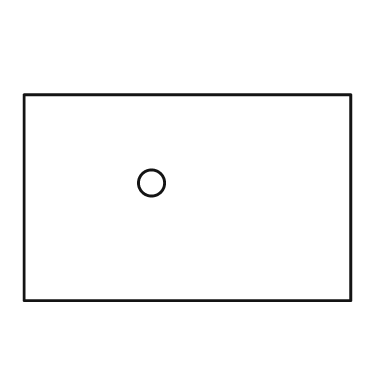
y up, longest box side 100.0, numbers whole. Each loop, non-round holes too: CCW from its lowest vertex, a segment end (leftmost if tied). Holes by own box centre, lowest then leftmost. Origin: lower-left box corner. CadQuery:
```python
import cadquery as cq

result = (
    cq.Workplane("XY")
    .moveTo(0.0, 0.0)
    .lineTo(100.0, 0.0)
    .lineTo(100.0, 63.0)
    .lineTo(0.0, 63.0)
    .close()
    .moveTo(39.0, 36.0)
    .circle(4.0)
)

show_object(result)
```